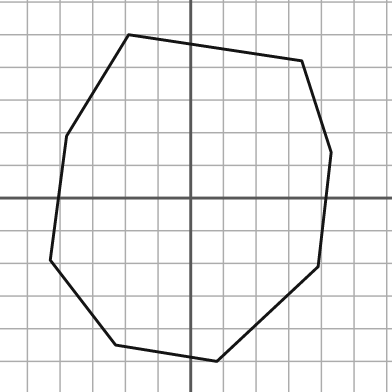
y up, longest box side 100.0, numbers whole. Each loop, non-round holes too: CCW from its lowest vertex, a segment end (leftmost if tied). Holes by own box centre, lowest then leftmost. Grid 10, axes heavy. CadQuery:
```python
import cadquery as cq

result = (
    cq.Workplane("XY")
    .moveTo(8.0, -50.0)
    .lineTo(39.0, -21.0)
    .lineTo(43.0, 14.0)
    .lineTo(34.0, 42.0)
    .lineTo(-19.0, 50.0)
    .lineTo(-38.0, 19.0)
    .lineTo(-43.0, -19.0)
    .lineTo(-23.0, -45.0)
    .close()
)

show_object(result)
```